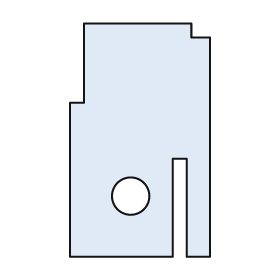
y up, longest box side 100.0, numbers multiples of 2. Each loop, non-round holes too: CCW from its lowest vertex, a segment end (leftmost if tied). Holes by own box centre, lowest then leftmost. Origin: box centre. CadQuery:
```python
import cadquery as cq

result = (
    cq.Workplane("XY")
    .moveTo(-30.0, -50.0)
    .lineTo(14.0, -50.0)
    .lineTo(14.0, -8.0)
    .lineTo(20.0, -8.0)
    .lineTo(20.0, -50.0)
    .lineTo(30.0, -50.0)
    .lineTo(30.0, 44.0)
    .lineTo(22.0, 44.0)
    .lineTo(22.0, 50.0)
    .lineTo(-24.0, 50.0)
    .lineTo(-24.0, 16.0)
    .lineTo(-30.0, 16.0)
    .close()
    .moveTo(-4.0, -24.0)
    .circle(8.0)
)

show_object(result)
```